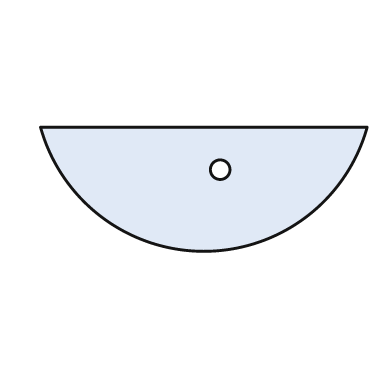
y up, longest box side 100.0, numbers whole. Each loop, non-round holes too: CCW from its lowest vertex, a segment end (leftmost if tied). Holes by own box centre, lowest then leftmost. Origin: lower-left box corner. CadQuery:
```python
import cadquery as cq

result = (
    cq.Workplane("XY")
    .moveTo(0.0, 38.0)
    .threePointArc((50.0, 0.0), (100.0, 38.0))
    .close()
    .moveTo(55.0, 25.0)
    .circle(3.0)
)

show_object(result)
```